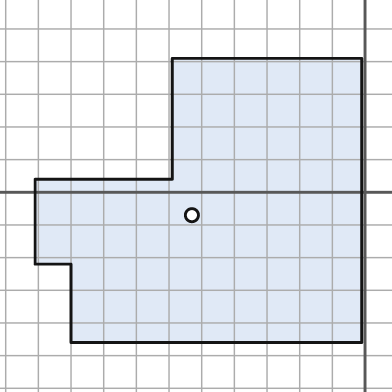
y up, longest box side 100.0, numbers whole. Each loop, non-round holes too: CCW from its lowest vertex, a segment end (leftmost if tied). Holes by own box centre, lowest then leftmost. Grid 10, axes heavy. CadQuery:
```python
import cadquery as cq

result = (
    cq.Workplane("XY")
    .moveTo(-90.0, -46.0)
    .lineTo(-1.0, -46.0)
    .lineTo(-1.0, 41.0)
    .lineTo(-59.0, 41.0)
    .lineTo(-59.0, 4.0)
    .lineTo(-101.0, 4.0)
    .lineTo(-101.0, -22.0)
    .lineTo(-90.0, -22.0)
    .close()
    .moveTo(-53.0, -7.0)
    .circle(2.0)
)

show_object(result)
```